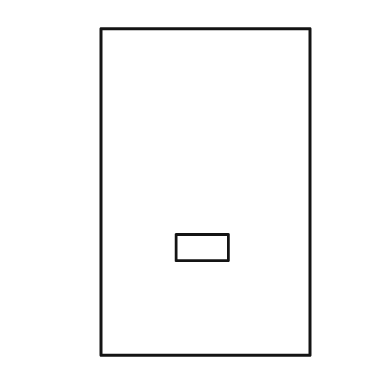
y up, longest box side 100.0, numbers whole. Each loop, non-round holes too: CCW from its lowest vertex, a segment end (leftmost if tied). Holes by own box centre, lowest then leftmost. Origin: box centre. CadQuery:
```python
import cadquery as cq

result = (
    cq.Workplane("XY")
    .moveTo(-32.0, -50.0)
    .lineTo(32.0, -50.0)
    .lineTo(32.0, 50.0)
    .lineTo(-32.0, 50.0)
    .close()
    .moveTo(-9.0, -21.0)
    .lineTo(7.0, -21.0)
    .lineTo(7.0, -13.0)
    .lineTo(-9.0, -13.0)
    .close()
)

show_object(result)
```